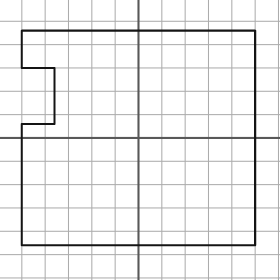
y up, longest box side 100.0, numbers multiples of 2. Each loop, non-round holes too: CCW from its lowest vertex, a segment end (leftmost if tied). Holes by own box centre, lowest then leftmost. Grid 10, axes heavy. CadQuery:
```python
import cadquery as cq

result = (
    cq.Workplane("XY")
    .moveTo(-50.0, -46.0)
    .lineTo(50.0, -46.0)
    .lineTo(50.0, 46.0)
    .lineTo(-50.0, 46.0)
    .lineTo(-50.0, 30.0)
    .lineTo(-36.0, 30.0)
    .lineTo(-36.0, 6.0)
    .lineTo(-50.0, 6.0)
    .close()
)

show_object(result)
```